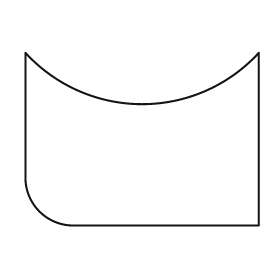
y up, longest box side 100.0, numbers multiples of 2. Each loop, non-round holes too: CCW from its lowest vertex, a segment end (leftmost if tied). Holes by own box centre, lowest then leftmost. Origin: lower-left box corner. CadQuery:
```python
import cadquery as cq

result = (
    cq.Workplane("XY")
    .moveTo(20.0, 0.0)
    .lineTo(100.0, 0.0)
    .lineTo(100.0, 74.0)
    .threePointArc((50.0, 52.0), (0.0, 74.0))
    .lineTo(0.0, 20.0)
    .threePointArc((6.0, 6.0), (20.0, 0.0))
    .close()
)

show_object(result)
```